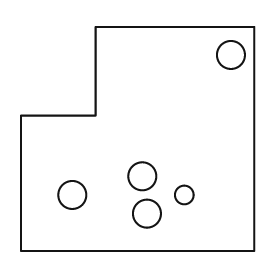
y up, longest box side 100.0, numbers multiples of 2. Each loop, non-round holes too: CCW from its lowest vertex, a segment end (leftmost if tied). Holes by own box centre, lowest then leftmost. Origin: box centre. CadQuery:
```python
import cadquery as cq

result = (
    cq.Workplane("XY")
    .moveTo(-50.0, -48.0)
    .lineTo(50.0, -48.0)
    .lineTo(50.0, 48.0)
    .lineTo(-18.0, 48.0)
    .lineTo(-18.0, 10.0)
    .lineTo(-50.0, 10.0)
    .close()
    .moveTo(4.0, -32.0)
    .circle(6.0)
    .moveTo(-28.0, -24.0)
    .circle(6.0)
    .moveTo(20.0, -24.0)
    .circle(4.0)
    .moveTo(2.0, -16.0)
    .circle(6.0)
    .moveTo(40.0, 36.0)
    .circle(6.0)
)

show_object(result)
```